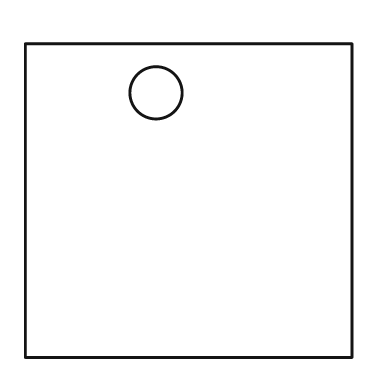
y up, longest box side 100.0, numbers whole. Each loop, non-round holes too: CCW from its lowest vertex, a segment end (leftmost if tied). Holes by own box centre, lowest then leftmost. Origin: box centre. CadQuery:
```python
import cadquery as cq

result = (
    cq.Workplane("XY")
    .moveTo(-50.0, -48.0)
    .lineTo(50.0, -48.0)
    .lineTo(50.0, 48.0)
    .lineTo(-50.0, 48.0)
    .close()
    .moveTo(-10.0, 33.0)
    .circle(8.0)
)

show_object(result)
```